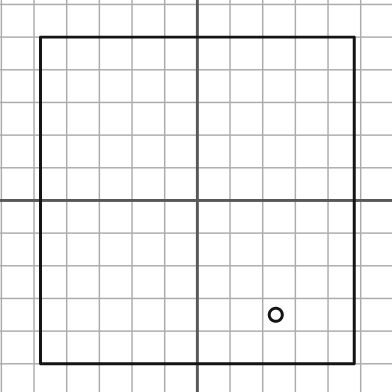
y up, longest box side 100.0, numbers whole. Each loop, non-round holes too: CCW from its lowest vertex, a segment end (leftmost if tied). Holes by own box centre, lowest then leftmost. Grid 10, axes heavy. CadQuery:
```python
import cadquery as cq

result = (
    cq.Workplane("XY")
    .moveTo(-48.0, -50.0)
    .lineTo(48.0, -50.0)
    .lineTo(48.0, 50.0)
    .lineTo(-48.0, 50.0)
    .close()
    .moveTo(24.0, -35.0)
    .circle(2.0)
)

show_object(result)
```